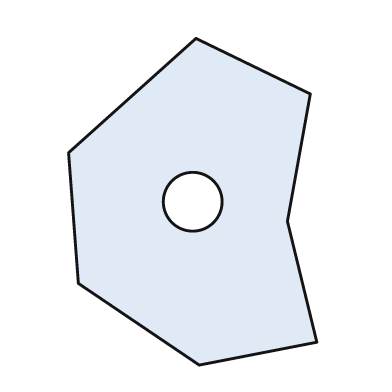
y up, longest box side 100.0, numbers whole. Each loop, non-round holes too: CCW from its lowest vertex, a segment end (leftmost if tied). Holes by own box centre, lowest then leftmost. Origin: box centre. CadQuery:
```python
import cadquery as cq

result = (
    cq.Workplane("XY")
    .moveTo(2.0, -50.0)
    .lineTo(38.0, -43.0)
    .lineTo(29.0, -6.0)
    .lineTo(36.0, 33.0)
    .lineTo(1.0, 50.0)
    .lineTo(-38.0, 15.0)
    .lineTo(-35.0, -25.0)
    .close()
    .moveTo(0.0, 0.0)
    .circle(9.0)
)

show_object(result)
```